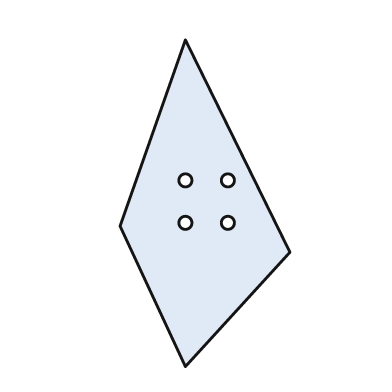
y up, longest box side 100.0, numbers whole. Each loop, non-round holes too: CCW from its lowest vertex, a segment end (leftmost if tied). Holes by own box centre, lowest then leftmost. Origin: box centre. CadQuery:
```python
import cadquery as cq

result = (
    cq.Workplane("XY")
    .moveTo(-6.0, -50.0)
    .lineTo(26.0, -15.0)
    .lineTo(-6.0, 50.0)
    .lineTo(-26.0, -7.0)
    .close()
    .moveTo(-6.0, -6.0)
    .circle(2.0)
    .moveTo(7.0, -6.0)
    .circle(2.0)
    .moveTo(-6.0, 7.0)
    .circle(2.0)
    .moveTo(7.0, 7.0)
    .circle(2.0)
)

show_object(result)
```